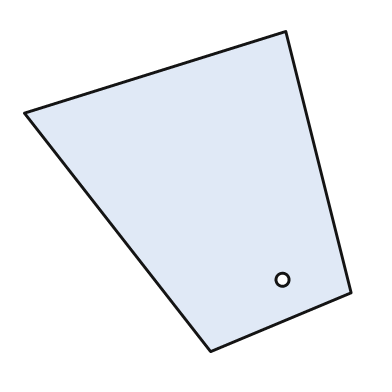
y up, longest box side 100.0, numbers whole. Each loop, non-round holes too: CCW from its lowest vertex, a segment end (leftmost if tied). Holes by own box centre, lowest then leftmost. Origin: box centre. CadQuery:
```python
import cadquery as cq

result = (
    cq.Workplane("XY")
    .moveTo(7.0, -49.0)
    .lineTo(50.0, -31.0)
    .lineTo(30.0, 49.0)
    .lineTo(-50.0, 24.0)
    .close()
    .moveTo(29.0, -27.0)
    .circle(2.0)
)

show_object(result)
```